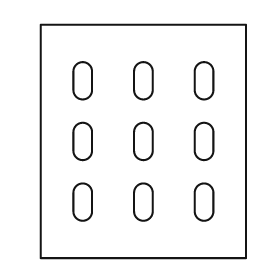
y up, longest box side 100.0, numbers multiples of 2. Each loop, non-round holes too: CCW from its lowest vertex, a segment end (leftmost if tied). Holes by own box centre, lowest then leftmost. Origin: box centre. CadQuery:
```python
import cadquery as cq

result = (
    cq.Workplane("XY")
    .moveTo(-44.0, -50.0)
    .lineTo(44.0, -50.0)
    .lineTo(44.0, 50.0)
    .lineTo(-44.0, 50.0)
    .close()
    .moveTo(-30.0, -30.0)
    .threePointArc((-26.0, -34.0), (-22.0, -30.0))
    .lineTo(-22.0, -22.0)
    .threePointArc((-26.0, -18.0), (-30.0, -22.0))
    .close()
    .moveTo(-4.0, -30.0)
    .threePointArc((0.0, -34.0), (4.0, -30.0))
    .lineTo(4.0, -22.0)
    .threePointArc((0.0, -18.0), (-4.0, -22.0))
    .close()
    .moveTo(22.0, -30.0)
    .threePointArc((26.0, -34.0), (30.0, -30.0))
    .lineTo(30.0, -22.0)
    .threePointArc((26.0, -18.0), (22.0, -22.0))
    .close()
    .moveTo(-30.0, -4.0)
    .threePointArc((-26.0, -8.0), (-22.0, -4.0))
    .lineTo(-22.0, 4.0)
    .threePointArc((-26.0, 8.0), (-30.0, 4.0))
    .close()
    .moveTo(-4.0, -4.0)
    .threePointArc((0.0, -8.0), (4.0, -4.0))
    .lineTo(4.0, 4.0)
    .threePointArc((0.0, 8.0), (-4.0, 4.0))
    .close()
    .moveTo(22.0, -4.0)
    .threePointArc((26.0, -8.0), (30.0, -4.0))
    .lineTo(30.0, 4.0)
    .threePointArc((26.0, 8.0), (22.0, 4.0))
    .close()
    .moveTo(-30.0, 22.0)
    .threePointArc((-26.0, 18.0), (-22.0, 22.0))
    .lineTo(-22.0, 30.0)
    .threePointArc((-26.0, 34.0), (-30.0, 30.0))
    .close()
    .moveTo(-4.0, 22.0)
    .threePointArc((0.0, 18.0), (4.0, 22.0))
    .lineTo(4.0, 30.0)
    .threePointArc((0.0, 34.0), (-4.0, 30.0))
    .close()
    .moveTo(22.0, 22.0)
    .threePointArc((26.0, 18.0), (30.0, 22.0))
    .lineTo(30.0, 30.0)
    .threePointArc((26.0, 34.0), (22.0, 30.0))
    .close()
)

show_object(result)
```